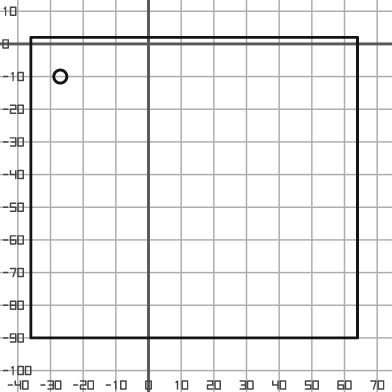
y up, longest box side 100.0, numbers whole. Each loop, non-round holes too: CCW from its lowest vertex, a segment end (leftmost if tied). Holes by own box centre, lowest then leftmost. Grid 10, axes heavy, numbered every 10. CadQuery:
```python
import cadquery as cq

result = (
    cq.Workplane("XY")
    .moveTo(-36.0, -90.0)
    .lineTo(64.0, -90.0)
    .lineTo(64.0, 2.0)
    .lineTo(-36.0, 2.0)
    .close()
    .moveTo(-27.0, -10.0)
    .circle(2.0)
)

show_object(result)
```